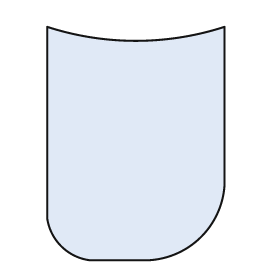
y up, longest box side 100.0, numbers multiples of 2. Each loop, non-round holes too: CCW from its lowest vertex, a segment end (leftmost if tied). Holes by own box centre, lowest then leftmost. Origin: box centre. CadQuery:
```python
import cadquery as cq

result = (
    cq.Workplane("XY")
    .moveTo(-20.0, -50.0)
    .lineTo(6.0, -50.0)
    .threePointArc((28.0, -40.0), (38.0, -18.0))
    .lineTo(38.0, 50.0)
    .threePointArc((0.0, 44.0), (-38.0, 50.0))
    .lineTo(-38.0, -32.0)
    .threePointArc((-32.0, -44.0), (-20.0, -50.0))
    .close()
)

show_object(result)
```